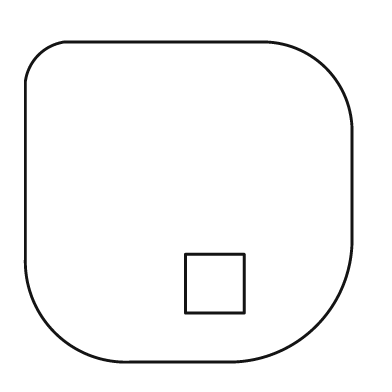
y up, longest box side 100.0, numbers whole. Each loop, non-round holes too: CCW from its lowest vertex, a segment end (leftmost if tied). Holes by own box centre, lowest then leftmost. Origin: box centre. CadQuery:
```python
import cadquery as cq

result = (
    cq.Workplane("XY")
    .moveTo(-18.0, -49.0)
    .lineTo(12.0, -49.0)
    .threePointArc((39.0, -38.0), (50.0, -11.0))
    .lineTo(50.0, 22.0)
    .threePointArc((42.0, 41.0), (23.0, 49.0))
    .lineTo(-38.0, 49.0)
    .threePointArc((-46.0, 45.0), (-50.0, 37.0))
    .lineTo(-50.0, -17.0)
    .threePointArc((-41.0, -40.0), (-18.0, -49.0))
    .close()
    .moveTo(-1.0, -34.0)
    .lineTo(17.0, -34.0)
    .lineTo(17.0, -16.0)
    .lineTo(-1.0, -16.0)
    .close()
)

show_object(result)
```